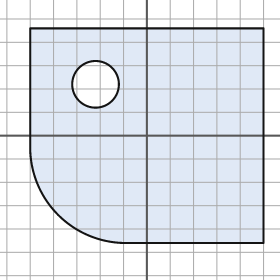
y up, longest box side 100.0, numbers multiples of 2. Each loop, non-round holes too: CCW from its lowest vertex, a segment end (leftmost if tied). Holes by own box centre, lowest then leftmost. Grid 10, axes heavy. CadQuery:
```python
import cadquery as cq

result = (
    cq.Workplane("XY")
    .moveTo(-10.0, -46.0)
    .lineTo(50.0, -46.0)
    .lineTo(50.0, 46.0)
    .lineTo(-50.0, 46.0)
    .lineTo(-50.0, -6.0)
    .threePointArc((-38.0, -34.0), (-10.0, -46.0))
    .close()
    .moveTo(-22.0, 22.0)
    .circle(10.0)
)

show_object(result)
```